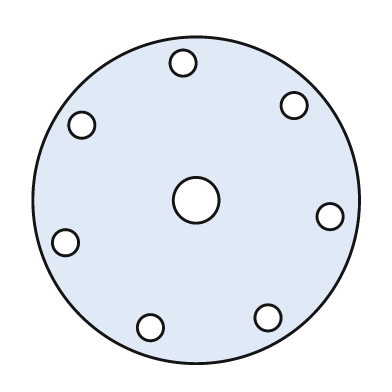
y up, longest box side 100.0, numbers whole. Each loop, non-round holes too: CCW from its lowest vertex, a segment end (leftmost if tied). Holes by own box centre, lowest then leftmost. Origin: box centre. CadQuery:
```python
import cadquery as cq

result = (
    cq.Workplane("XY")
    .moveTo(0.0, 0.0)
    .circle(50.0)
    .moveTo(-14.0, -39.0)
    .circle(4.0)
    .moveTo(22.0, -36.0)
    .circle(4.0)
    .moveTo(-40.0, -13.0)
    .circle(4.0)
    .moveTo(41.0, -5.0)
    .circle(4.0)
    .moveTo(0.0, 0.0)
    .circle(7.0)
    .moveTo(-35.0, 23.0)
    .circle(4.0)
    .moveTo(30.0, 29.0)
    .circle(4.0)
    .moveTo(-4.0, 42.0)
    .circle(4.0)
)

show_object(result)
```